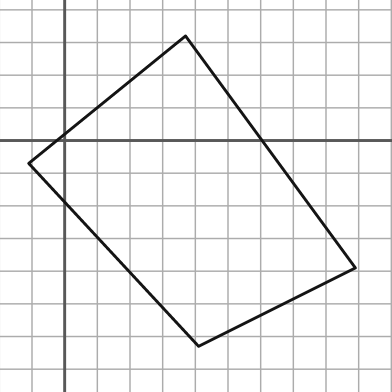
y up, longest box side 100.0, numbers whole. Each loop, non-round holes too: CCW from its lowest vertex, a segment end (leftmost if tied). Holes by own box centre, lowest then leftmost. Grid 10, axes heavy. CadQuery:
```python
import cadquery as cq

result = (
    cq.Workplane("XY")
    .moveTo(41.0, -63.0)
    .lineTo(89.0, -39.0)
    .lineTo(37.0, 32.0)
    .lineTo(-11.0, -7.0)
    .close()
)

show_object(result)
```